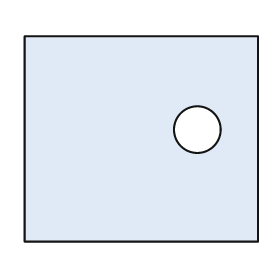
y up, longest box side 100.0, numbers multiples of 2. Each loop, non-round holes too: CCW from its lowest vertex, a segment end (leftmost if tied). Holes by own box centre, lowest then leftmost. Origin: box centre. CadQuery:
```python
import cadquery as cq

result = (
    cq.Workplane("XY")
    .moveTo(-50.0, -44.0)
    .lineTo(50.0, -44.0)
    .lineTo(50.0, 44.0)
    .lineTo(-50.0, 44.0)
    .close()
    .moveTo(24.0, 4.0)
    .circle(10.0)
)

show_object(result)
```